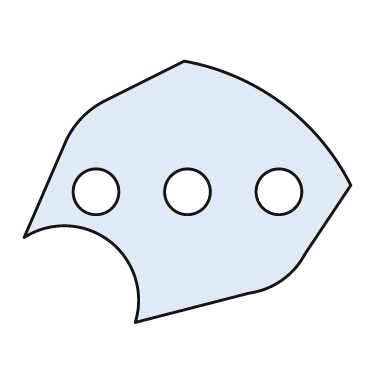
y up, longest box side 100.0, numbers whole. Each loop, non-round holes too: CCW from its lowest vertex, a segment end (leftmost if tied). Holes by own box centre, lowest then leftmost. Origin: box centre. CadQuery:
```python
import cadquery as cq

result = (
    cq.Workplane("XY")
    .moveTo(-16.0, -40.0)
    .lineTo(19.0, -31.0)
    .threePointArc((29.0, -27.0), (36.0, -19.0))
    .lineTo(50.0, 2.0)
    .threePointArc((29.0, 27.0), (-1.0, 40.0))
    .lineTo(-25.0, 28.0)
    .threePointArc((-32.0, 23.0), (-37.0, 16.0))
    .lineTo(-50.0, -14.0)
    .threePointArc((-24.0, -15.0), (-16.0, -40.0))
    .close()
    .moveTo(-28.0, 0.0)
    .circle(7.0)
    .moveTo(0.0, 0.0)
    .circle(7.0)
    .moveTo(28.0, 0.0)
    .circle(7.0)
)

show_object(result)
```